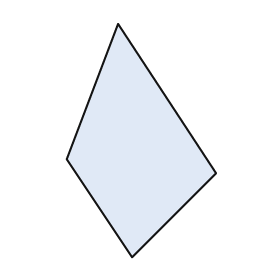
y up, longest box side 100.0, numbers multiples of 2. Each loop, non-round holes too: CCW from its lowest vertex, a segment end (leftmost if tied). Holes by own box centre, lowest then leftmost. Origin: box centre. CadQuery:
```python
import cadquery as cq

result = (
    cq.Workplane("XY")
    .moveTo(-4.0, -50.0)
    .lineTo(32.0, -14.0)
    .lineTo(-10.0, 50.0)
    .lineTo(-32.0, -8.0)
    .close()
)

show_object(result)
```